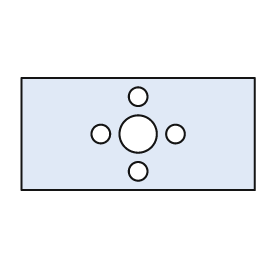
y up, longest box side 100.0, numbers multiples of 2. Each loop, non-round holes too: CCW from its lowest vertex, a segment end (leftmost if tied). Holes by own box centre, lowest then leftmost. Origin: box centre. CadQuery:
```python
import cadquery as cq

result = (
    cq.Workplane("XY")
    .moveTo(-50.0, -24.0)
    .lineTo(50.0, -24.0)
    .lineTo(50.0, 24.0)
    .lineTo(-50.0, 24.0)
    .close()
    .moveTo(0.0, -16.0)
    .circle(4.0)
    .moveTo(-16.0, 0.0)
    .circle(4.0)
    .moveTo(0.0, 0.0)
    .circle(8.0)
    .moveTo(16.0, 0.0)
    .circle(4.0)
    .moveTo(0.0, 16.0)
    .circle(4.0)
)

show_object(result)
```